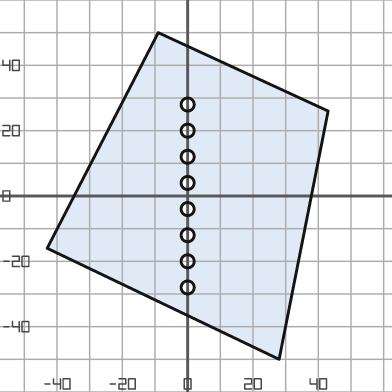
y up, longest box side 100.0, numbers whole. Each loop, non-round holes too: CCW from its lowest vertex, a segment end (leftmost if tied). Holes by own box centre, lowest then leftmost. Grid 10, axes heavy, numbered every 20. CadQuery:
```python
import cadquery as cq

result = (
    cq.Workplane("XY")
    .moveTo(28.0, -50.0)
    .lineTo(43.0, 26.0)
    .lineTo(-9.0, 50.0)
    .lineTo(-43.0, -16.0)
    .close()
    .moveTo(0.0, -28.0)
    .circle(2.0)
    .moveTo(0.0, -20.0)
    .circle(2.0)
    .moveTo(0.0, -12.0)
    .circle(2.0)
    .moveTo(0.0, -4.0)
    .circle(2.0)
    .moveTo(0.0, 4.0)
    .circle(2.0)
    .moveTo(0.0, 12.0)
    .circle(2.0)
    .moveTo(0.0, 20.0)
    .circle(2.0)
    .moveTo(0.0, 28.0)
    .circle(2.0)
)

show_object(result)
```